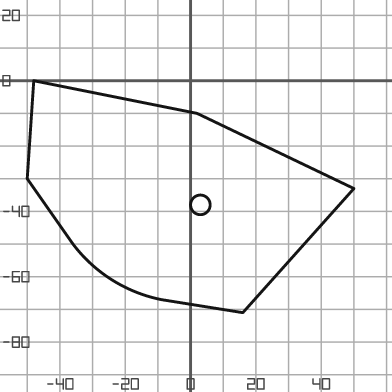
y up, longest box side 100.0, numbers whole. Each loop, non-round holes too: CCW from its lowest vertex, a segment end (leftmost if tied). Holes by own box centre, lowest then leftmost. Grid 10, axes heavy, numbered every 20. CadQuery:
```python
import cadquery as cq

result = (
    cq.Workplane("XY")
    .moveTo(16.0, -71.0)
    .lineTo(50.0, -33.0)
    .lineTo(2.0, -10.0)
    .lineTo(-48.0, 0.0)
    .lineTo(-50.0, -30.0)
    .lineTo(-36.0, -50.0)
    .threePointArc((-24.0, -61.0), (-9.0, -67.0))
    .close()
    .moveTo(3.0, -38.0)
    .circle(3.0)
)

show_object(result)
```